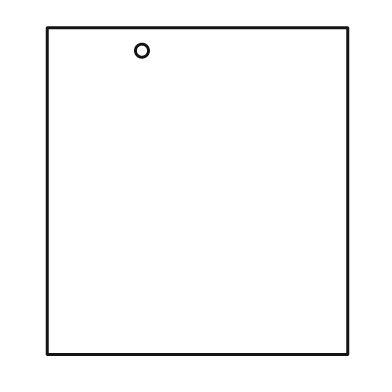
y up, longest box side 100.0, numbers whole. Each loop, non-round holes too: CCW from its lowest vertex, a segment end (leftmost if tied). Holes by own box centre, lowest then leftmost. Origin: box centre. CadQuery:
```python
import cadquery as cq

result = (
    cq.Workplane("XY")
    .moveTo(-46.0, -50.0)
    .lineTo(46.0, -50.0)
    .lineTo(46.0, 50.0)
    .lineTo(-46.0, 50.0)
    .close()
    .moveTo(-17.0, 43.0)
    .circle(2.0)
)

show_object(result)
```